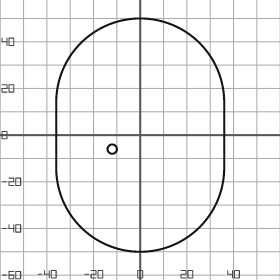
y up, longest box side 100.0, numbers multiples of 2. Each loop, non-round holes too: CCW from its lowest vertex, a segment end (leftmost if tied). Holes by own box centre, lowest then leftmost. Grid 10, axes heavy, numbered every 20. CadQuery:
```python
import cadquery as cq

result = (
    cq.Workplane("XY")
    .moveTo(-36.0, -14.0)
    .threePointArc((0.0, -50.0), (36.0, -14.0))
    .lineTo(36.0, 14.0)
    .threePointArc((0.0, 50.0), (-36.0, 14.0))
    .close()
    .moveTo(-12.0, -6.0)
    .circle(2.0)
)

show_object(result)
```